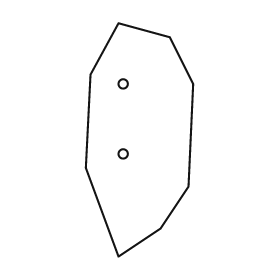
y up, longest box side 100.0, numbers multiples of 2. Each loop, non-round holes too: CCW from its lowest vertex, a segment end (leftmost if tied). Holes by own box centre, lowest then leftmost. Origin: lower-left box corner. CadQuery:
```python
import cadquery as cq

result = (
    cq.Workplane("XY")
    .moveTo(14.0, 0.0)
    .lineTo(32.0, 12.0)
    .lineTo(44.0, 30.0)
    .lineTo(46.0, 74.0)
    .lineTo(36.0, 94.0)
    .lineTo(14.0, 100.0)
    .lineTo(2.0, 78.0)
    .lineTo(0.0, 38.0)
    .close()
    .moveTo(16.0, 44.0)
    .circle(2.0)
    .moveTo(16.0, 74.0)
    .circle(2.0)
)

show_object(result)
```